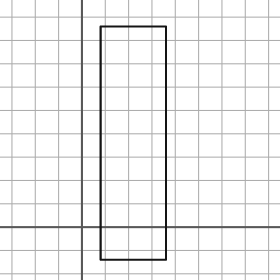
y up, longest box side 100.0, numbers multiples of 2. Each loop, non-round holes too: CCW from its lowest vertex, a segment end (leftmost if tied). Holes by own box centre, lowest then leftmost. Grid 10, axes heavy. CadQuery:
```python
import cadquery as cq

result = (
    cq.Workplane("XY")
    .moveTo(8.0, -14.0)
    .lineTo(36.0, -14.0)
    .lineTo(36.0, 86.0)
    .lineTo(8.0, 86.0)
    .close()
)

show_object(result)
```